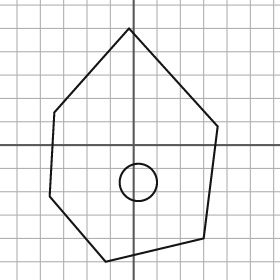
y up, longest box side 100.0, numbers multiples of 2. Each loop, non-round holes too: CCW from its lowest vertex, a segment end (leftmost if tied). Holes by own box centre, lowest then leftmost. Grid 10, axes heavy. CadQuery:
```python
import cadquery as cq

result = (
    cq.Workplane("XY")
    .moveTo(-12.0, -50.0)
    .lineTo(30.0, -40.0)
    .lineTo(36.0, 8.0)
    .lineTo(-2.0, 50.0)
    .lineTo(-34.0, 14.0)
    .lineTo(-36.0, -22.0)
    .close()
    .moveTo(2.0, -16.0)
    .circle(8.0)
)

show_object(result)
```